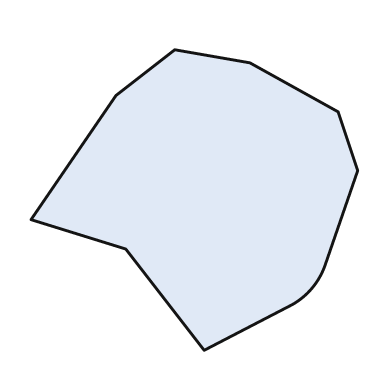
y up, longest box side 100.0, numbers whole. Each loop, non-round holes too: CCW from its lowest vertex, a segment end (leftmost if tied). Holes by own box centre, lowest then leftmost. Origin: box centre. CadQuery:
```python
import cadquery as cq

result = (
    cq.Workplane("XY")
    .moveTo(3.0, -46.0)
    .lineTo(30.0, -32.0)
    .threePointArc((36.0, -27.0), (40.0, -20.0))
    .lineTo(50.0, 9.0)
    .lineTo(44.0, 27.0)
    .lineTo(17.0, 42.0)
    .lineTo(-6.0, 46.0)
    .lineTo(-24.0, 32.0)
    .lineTo(-50.0, -6.0)
    .lineTo(-21.0, -15.0)
    .close()
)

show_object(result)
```